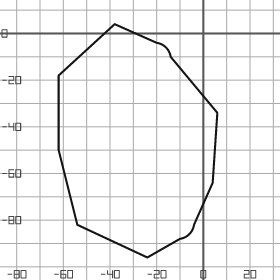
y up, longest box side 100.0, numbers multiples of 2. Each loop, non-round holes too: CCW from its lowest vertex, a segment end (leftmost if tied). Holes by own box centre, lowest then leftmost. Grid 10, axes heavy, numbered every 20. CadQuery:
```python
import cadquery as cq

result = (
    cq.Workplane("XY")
    .moveTo(-24.0, -96.0)
    .lineTo(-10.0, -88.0)
    .threePointArc((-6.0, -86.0), (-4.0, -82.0))
    .lineTo(4.0, -64.0)
    .lineTo(6.0, -34.0)
    .lineTo(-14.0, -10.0)
    .threePointArc((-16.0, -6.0), (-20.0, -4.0))
    .lineTo(-38.0, 4.0)
    .lineTo(-62.0, -18.0)
    .lineTo(-62.0, -50.0)
    .lineTo(-54.0, -82.0)
    .close()
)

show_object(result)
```